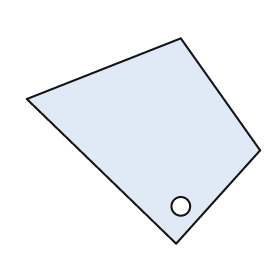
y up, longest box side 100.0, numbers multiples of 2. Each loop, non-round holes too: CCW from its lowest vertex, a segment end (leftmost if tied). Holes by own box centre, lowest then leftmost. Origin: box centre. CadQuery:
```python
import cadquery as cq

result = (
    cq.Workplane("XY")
    .moveTo(14.0, -44.0)
    .lineTo(50.0, -4.0)
    .lineTo(16.0, 44.0)
    .lineTo(-50.0, 18.0)
    .close()
    .moveTo(16.0, -28.0)
    .circle(4.0)
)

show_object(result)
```